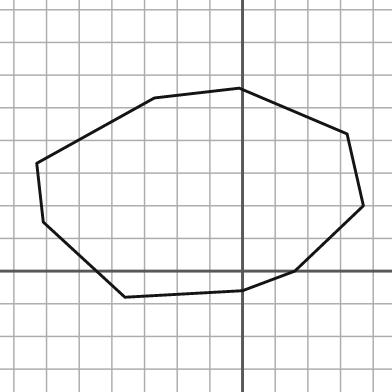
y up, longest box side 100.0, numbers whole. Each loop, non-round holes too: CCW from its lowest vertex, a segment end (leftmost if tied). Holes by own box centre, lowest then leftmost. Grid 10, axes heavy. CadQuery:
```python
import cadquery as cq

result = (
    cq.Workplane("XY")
    .moveTo(-36.0, -8.0)
    .lineTo(0.0, -6.0)
    .lineTo(16.0, 0.0)
    .lineTo(37.0, 20.0)
    .lineTo(32.0, 42.0)
    .lineTo(-1.0, 56.0)
    .lineTo(-27.0, 53.0)
    .lineTo(-63.0, 33.0)
    .lineTo(-61.0, 15.0)
    .close()
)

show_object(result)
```